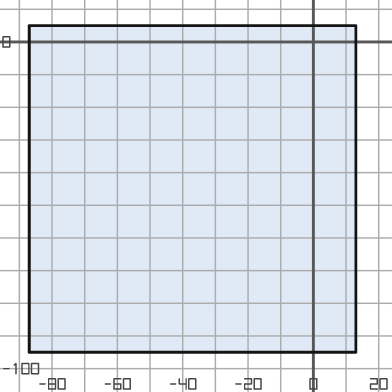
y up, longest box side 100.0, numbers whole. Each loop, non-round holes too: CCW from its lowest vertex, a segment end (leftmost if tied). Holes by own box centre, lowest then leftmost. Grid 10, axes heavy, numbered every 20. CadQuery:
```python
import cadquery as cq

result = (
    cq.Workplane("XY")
    .moveTo(-87.0, -95.0)
    .lineTo(13.0, -95.0)
    .lineTo(13.0, 5.0)
    .lineTo(-87.0, 5.0)
    .close()
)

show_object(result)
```